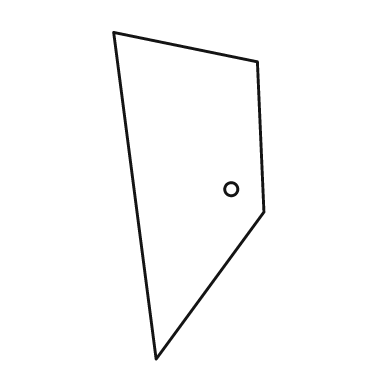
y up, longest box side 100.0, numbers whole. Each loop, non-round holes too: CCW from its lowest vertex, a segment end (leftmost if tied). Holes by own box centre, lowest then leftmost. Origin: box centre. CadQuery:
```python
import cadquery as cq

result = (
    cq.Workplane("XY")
    .moveTo(-10.0, -50.0)
    .lineTo(23.0, -5.0)
    .lineTo(21.0, 41.0)
    .lineTo(-23.0, 50.0)
    .close()
    .moveTo(13.0, 2.0)
    .circle(2.0)
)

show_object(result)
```